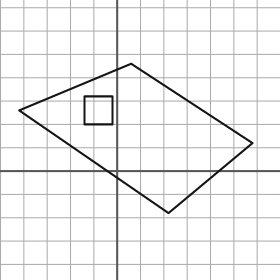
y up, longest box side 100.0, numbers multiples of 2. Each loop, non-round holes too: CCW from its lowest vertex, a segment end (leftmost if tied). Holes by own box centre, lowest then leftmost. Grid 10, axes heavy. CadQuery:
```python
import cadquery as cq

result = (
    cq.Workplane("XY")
    .moveTo(22.0, -18.0)
    .lineTo(58.0, 12.0)
    .lineTo(6.0, 46.0)
    .lineTo(-42.0, 26.0)
    .close()
    .moveTo(-14.0, 20.0)
    .lineTo(-2.0, 20.0)
    .lineTo(-2.0, 32.0)
    .lineTo(-14.0, 32.0)
    .close()
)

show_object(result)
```